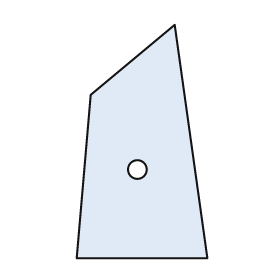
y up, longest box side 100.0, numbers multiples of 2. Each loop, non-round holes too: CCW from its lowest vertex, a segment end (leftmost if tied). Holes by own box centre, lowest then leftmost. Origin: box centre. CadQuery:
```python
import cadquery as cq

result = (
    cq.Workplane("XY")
    .moveTo(-28.0, -50.0)
    .lineTo(28.0, -50.0)
    .lineTo(14.0, 50.0)
    .lineTo(-22.0, 20.0)
    .close()
    .moveTo(-2.0, -12.0)
    .circle(4.0)
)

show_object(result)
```